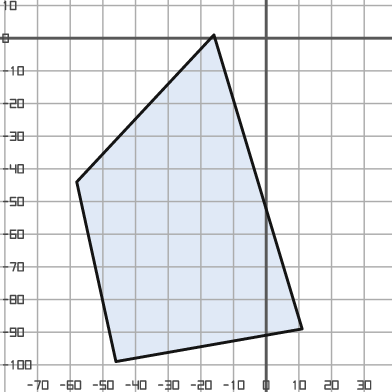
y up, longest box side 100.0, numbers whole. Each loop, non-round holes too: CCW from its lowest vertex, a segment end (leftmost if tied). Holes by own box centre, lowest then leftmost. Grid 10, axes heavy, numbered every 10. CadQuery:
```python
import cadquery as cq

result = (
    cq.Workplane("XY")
    .moveTo(-46.0, -99.0)
    .lineTo(11.0, -89.0)
    .lineTo(-16.0, 1.0)
    .lineTo(-58.0, -44.0)
    .close()
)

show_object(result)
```